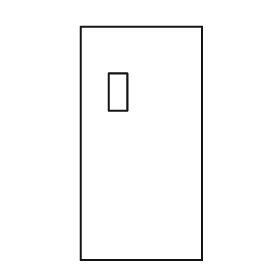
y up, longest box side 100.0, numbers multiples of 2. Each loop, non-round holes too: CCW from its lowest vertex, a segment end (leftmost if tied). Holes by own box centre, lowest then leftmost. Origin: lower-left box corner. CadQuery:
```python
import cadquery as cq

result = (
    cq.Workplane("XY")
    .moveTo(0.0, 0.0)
    .lineTo(52.0, 0.0)
    .lineTo(52.0, 100.0)
    .lineTo(0.0, 100.0)
    .close()
    .moveTo(12.0, 64.0)
    .lineTo(20.0, 64.0)
    .lineTo(20.0, 80.0)
    .lineTo(12.0, 80.0)
    .close()
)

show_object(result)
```